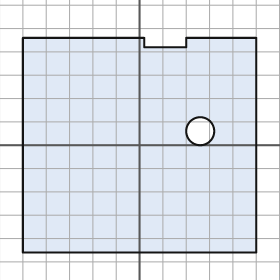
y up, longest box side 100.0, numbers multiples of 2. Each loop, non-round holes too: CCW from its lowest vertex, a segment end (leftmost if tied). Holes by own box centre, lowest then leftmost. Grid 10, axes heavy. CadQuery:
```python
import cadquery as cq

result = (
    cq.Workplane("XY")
    .moveTo(-50.0, -46.0)
    .lineTo(50.0, -46.0)
    .lineTo(50.0, 46.0)
    .lineTo(20.0, 46.0)
    .lineTo(20.0, 42.0)
    .lineTo(2.0, 42.0)
    .lineTo(2.0, 46.0)
    .lineTo(-50.0, 46.0)
    .close()
    .moveTo(26.0, 6.0)
    .circle(6.0)
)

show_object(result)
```